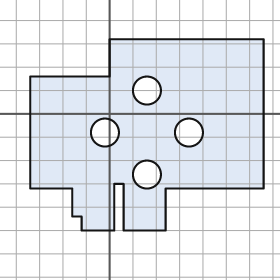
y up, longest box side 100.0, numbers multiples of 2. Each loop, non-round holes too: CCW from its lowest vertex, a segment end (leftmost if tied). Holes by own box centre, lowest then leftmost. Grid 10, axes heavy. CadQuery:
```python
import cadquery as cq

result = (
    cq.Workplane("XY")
    .moveTo(-12.0, -50.0)
    .lineTo(2.0, -50.0)
    .lineTo(2.0, -30.0)
    .lineTo(6.0, -30.0)
    .lineTo(6.0, -50.0)
    .lineTo(24.0, -50.0)
    .lineTo(24.0, -32.0)
    .lineTo(66.0, -32.0)
    .lineTo(66.0, 32.0)
    .lineTo(0.0, 32.0)
    .lineTo(0.0, 16.0)
    .lineTo(-34.0, 16.0)
    .lineTo(-34.0, -32.0)
    .lineTo(-16.0, -32.0)
    .lineTo(-16.0, -44.0)
    .lineTo(-12.0, -44.0)
    .close()
    .moveTo(16.0, -26.0)
    .circle(6.0)
    .moveTo(-2.0, -8.0)
    .circle(6.0)
    .moveTo(34.0, -8.0)
    .circle(6.0)
    .moveTo(16.0, 10.0)
    .circle(6.0)
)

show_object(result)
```